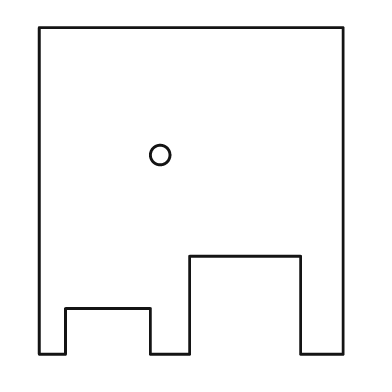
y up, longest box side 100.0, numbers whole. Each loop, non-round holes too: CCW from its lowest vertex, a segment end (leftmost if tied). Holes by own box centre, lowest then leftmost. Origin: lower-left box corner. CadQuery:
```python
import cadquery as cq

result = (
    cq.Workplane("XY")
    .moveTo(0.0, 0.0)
    .lineTo(8.0, 0.0)
    .lineTo(8.0, 14.0)
    .lineTo(34.0, 14.0)
    .lineTo(34.0, 0.0)
    .lineTo(46.0, 0.0)
    .lineTo(46.0, 30.0)
    .lineTo(80.0, 30.0)
    .lineTo(80.0, 0.0)
    .lineTo(93.0, 0.0)
    .lineTo(93.0, 100.0)
    .lineTo(0.0, 100.0)
    .close()
    .moveTo(37.0, 61.0)
    .circle(3.0)
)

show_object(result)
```